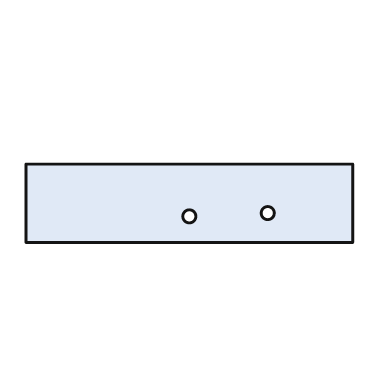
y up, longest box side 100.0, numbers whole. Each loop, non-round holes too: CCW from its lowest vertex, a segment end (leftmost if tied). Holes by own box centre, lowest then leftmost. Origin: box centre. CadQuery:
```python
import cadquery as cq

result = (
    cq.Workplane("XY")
    .moveTo(-50.0, -12.0)
    .lineTo(50.0, -12.0)
    .lineTo(50.0, 12.0)
    .lineTo(-50.0, 12.0)
    .close()
    .moveTo(0.0, -4.0)
    .circle(2.0)
    .moveTo(24.0, -3.0)
    .circle(2.0)
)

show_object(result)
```